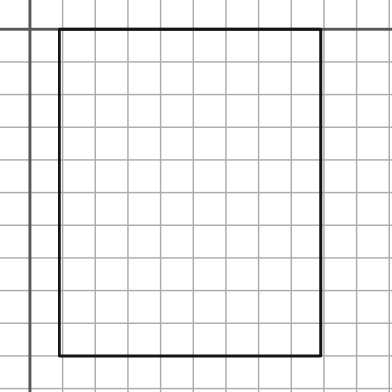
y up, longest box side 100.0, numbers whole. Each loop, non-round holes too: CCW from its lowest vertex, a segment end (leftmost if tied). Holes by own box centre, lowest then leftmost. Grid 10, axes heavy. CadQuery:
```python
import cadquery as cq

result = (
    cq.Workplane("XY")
    .moveTo(9.0, -100.0)
    .lineTo(89.0, -100.0)
    .lineTo(89.0, 0.0)
    .lineTo(9.0, 0.0)
    .close()
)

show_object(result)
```